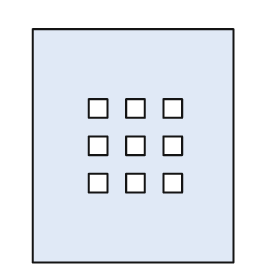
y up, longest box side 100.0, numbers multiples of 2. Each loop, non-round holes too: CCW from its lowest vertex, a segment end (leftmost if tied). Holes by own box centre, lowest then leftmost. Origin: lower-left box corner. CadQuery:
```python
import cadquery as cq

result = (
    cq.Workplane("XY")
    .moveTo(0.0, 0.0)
    .lineTo(86.0, 0.0)
    .lineTo(86.0, 100.0)
    .lineTo(0.0, 100.0)
    .close()
    .moveTo(24.0, 30.0)
    .lineTo(32.0, 30.0)
    .lineTo(32.0, 38.0)
    .lineTo(24.0, 38.0)
    .close()
    .moveTo(40.0, 30.0)
    .lineTo(48.0, 30.0)
    .lineTo(48.0, 38.0)
    .lineTo(40.0, 38.0)
    .close()
    .moveTo(56.0, 30.0)
    .lineTo(64.0, 30.0)
    .lineTo(64.0, 38.0)
    .lineTo(56.0, 38.0)
    .close()
    .moveTo(24.0, 46.0)
    .lineTo(32.0, 46.0)
    .lineTo(32.0, 54.0)
    .lineTo(24.0, 54.0)
    .close()
    .moveTo(40.0, 46.0)
    .lineTo(48.0, 46.0)
    .lineTo(48.0, 54.0)
    .lineTo(40.0, 54.0)
    .close()
    .moveTo(56.0, 46.0)
    .lineTo(64.0, 46.0)
    .lineTo(64.0, 54.0)
    .lineTo(56.0, 54.0)
    .close()
    .moveTo(24.0, 62.0)
    .lineTo(32.0, 62.0)
    .lineTo(32.0, 70.0)
    .lineTo(24.0, 70.0)
    .close()
    .moveTo(40.0, 62.0)
    .lineTo(48.0, 62.0)
    .lineTo(48.0, 70.0)
    .lineTo(40.0, 70.0)
    .close()
    .moveTo(56.0, 62.0)
    .lineTo(64.0, 62.0)
    .lineTo(64.0, 70.0)
    .lineTo(56.0, 70.0)
    .close()
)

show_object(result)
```